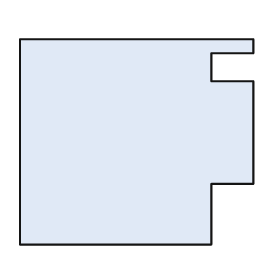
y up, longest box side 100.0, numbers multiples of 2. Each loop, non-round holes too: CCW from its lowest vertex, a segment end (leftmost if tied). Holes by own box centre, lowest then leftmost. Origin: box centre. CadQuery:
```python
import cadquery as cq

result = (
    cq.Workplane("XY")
    .moveTo(-50.0, -44.0)
    .lineTo(32.0, -44.0)
    .lineTo(32.0, -18.0)
    .lineTo(50.0, -18.0)
    .lineTo(50.0, 26.0)
    .lineTo(32.0, 26.0)
    .lineTo(32.0, 38.0)
    .lineTo(50.0, 38.0)
    .lineTo(50.0, 44.0)
    .lineTo(-50.0, 44.0)
    .close()
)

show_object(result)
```